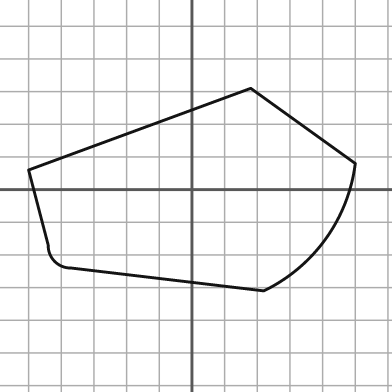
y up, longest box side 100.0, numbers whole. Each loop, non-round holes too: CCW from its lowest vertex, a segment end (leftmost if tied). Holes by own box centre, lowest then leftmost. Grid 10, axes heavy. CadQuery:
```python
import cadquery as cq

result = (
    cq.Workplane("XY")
    .moveTo(22.0, -31.0)
    .threePointArc((41.0, -15.0), (50.0, 8.0))
    .lineTo(18.0, 31.0)
    .lineTo(-50.0, 6.0)
    .lineTo(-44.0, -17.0)
    .threePointArc((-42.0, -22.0), (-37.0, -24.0))
    .close()
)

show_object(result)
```